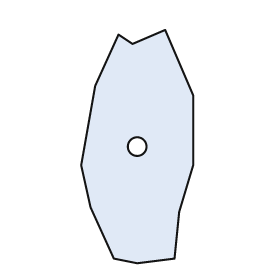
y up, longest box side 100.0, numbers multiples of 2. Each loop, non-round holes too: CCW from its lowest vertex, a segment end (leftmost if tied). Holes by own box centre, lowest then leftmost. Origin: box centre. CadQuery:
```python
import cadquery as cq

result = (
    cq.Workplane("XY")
    .moveTo(0.0, -50.0)
    .lineTo(16.0, -48.0)
    .lineTo(18.0, -28.0)
    .lineTo(24.0, -8.0)
    .lineTo(24.0, 22.0)
    .lineTo(12.0, 50.0)
    .lineTo(-2.0, 44.0)
    .lineTo(-8.0, 48.0)
    .lineTo(-18.0, 26.0)
    .lineTo(-24.0, -8.0)
    .lineTo(-20.0, -26.0)
    .lineTo(-10.0, -48.0)
    .close()
    .moveTo(0.0, 0.0)
    .circle(4.0)
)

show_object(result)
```